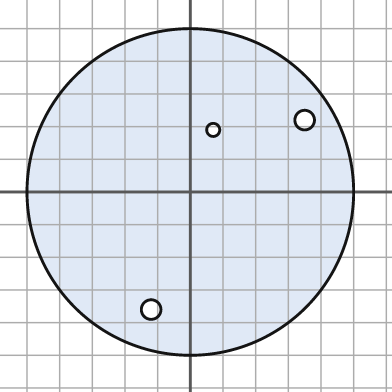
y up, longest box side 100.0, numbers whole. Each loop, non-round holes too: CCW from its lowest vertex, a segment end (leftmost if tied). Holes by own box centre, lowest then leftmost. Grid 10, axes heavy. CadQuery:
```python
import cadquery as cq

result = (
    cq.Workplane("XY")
    .moveTo(0.0, 0.0)
    .circle(50.0)
    .moveTo(-12.0, -36.0)
    .circle(3.0)
    .moveTo(7.0, 19.0)
    .circle(2.0)
    .moveTo(35.0, 22.0)
    .circle(3.0)
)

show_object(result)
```